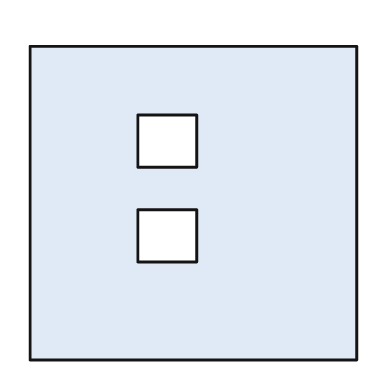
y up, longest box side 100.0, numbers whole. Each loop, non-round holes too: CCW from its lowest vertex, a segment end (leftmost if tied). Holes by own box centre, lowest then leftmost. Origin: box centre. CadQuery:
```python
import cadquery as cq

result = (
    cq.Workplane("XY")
    .moveTo(-50.0, -48.0)
    .lineTo(50.0, -48.0)
    .lineTo(50.0, 48.0)
    .lineTo(-50.0, 48.0)
    .close()
    .moveTo(-17.0, -18.0)
    .lineTo(1.0, -18.0)
    .lineTo(1.0, -2.0)
    .lineTo(-17.0, -2.0)
    .close()
    .moveTo(-17.0, 11.0)
    .lineTo(1.0, 11.0)
    .lineTo(1.0, 27.0)
    .lineTo(-17.0, 27.0)
    .close()
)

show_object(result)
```